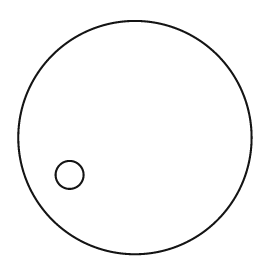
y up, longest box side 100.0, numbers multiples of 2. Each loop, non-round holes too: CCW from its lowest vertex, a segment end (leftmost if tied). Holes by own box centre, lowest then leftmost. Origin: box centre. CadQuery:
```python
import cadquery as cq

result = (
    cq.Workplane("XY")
    .moveTo(0.0, 0.0)
    .circle(50.0)
    .moveTo(-28.0, -16.0)
    .circle(6.0)
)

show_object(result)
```